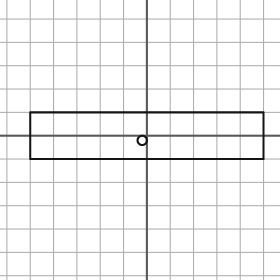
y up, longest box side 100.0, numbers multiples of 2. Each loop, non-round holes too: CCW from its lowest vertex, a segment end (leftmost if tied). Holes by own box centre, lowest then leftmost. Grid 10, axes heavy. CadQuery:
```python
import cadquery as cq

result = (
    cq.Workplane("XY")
    .moveTo(-50.0, -10.0)
    .lineTo(50.0, -10.0)
    .lineTo(50.0, 10.0)
    .lineTo(-50.0, 10.0)
    .close()
    .moveTo(-2.0, -2.0)
    .circle(2.0)
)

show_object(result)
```